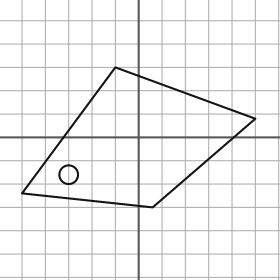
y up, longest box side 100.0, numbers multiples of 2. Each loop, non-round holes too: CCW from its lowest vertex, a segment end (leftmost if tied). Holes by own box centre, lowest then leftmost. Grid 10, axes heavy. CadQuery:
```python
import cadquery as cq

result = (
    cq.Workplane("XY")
    .moveTo(6.0, -30.0)
    .lineTo(50.0, 8.0)
    .lineTo(-10.0, 30.0)
    .lineTo(-50.0, -24.0)
    .close()
    .moveTo(-30.0, -16.0)
    .circle(4.0)
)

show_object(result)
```